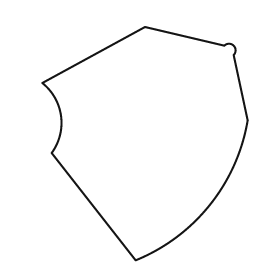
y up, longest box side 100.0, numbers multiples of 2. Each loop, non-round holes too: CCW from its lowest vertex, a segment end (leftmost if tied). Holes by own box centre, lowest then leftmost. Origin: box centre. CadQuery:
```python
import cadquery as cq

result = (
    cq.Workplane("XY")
    .moveTo(-4.0, -50.0)
    .threePointArc((28.0, -26.0), (44.0, 10.0))
    .lineTo(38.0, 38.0)
    .threePointArc((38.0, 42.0), (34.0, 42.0))
    .lineTo(0.0, 50.0)
    .lineTo(-44.0, 26.0)
    .threePointArc((-36.0, 12.0), (-40.0, -4.0))
    .close()
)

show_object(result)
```